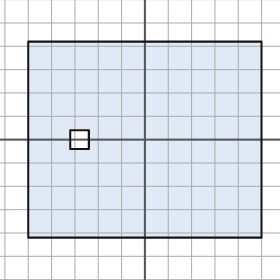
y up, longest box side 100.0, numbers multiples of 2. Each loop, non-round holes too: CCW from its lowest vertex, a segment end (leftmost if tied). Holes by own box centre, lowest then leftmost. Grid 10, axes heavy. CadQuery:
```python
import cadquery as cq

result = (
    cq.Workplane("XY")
    .moveTo(-50.0, -42.0)
    .lineTo(50.0, -42.0)
    .lineTo(50.0, 42.0)
    .lineTo(-50.0, 42.0)
    .close()
    .moveTo(-32.0, -4.0)
    .lineTo(-24.0, -4.0)
    .lineTo(-24.0, 4.0)
    .lineTo(-32.0, 4.0)
    .close()
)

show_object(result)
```